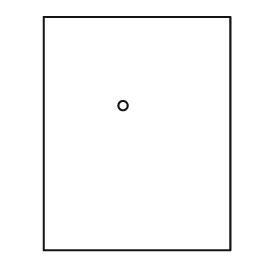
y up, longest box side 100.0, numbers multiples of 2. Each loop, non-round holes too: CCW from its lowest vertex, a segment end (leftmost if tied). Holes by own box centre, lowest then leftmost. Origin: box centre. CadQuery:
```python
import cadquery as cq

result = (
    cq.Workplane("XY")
    .moveTo(-40.0, -50.0)
    .lineTo(40.0, -50.0)
    .lineTo(40.0, 50.0)
    .lineTo(-40.0, 50.0)
    .close()
    .moveTo(-6.0, 12.0)
    .circle(2.0)
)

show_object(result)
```